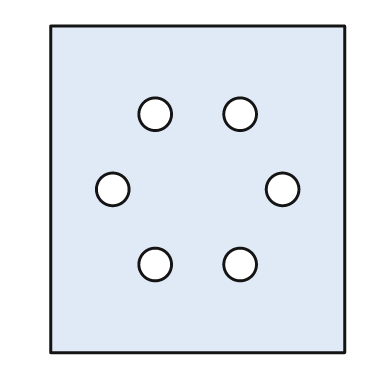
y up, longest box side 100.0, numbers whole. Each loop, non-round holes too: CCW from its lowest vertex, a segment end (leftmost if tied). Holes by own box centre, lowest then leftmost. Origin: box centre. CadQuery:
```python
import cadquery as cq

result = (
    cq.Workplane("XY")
    .moveTo(-45.0, -50.0)
    .lineTo(45.0, -50.0)
    .lineTo(45.0, 50.0)
    .lineTo(-45.0, 50.0)
    .close()
    .moveTo(-13.0, -23.0)
    .circle(5.0)
    .moveTo(13.0, -23.0)
    .circle(5.0)
    .moveTo(-26.0, 0.0)
    .circle(5.0)
    .moveTo(26.0, 0.0)
    .circle(5.0)
    .moveTo(-13.0, 23.0)
    .circle(5.0)
    .moveTo(13.0, 23.0)
    .circle(5.0)
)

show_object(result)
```